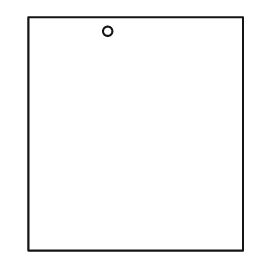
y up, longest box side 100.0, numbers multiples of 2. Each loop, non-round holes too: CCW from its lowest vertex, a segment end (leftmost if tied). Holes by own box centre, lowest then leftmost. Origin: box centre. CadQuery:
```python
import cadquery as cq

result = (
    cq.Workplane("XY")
    .moveTo(-46.0, -50.0)
    .lineTo(46.0, -50.0)
    .lineTo(46.0, 50.0)
    .lineTo(-46.0, 50.0)
    .close()
    .moveTo(-12.0, 44.0)
    .circle(2.0)
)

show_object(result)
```